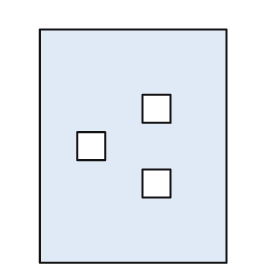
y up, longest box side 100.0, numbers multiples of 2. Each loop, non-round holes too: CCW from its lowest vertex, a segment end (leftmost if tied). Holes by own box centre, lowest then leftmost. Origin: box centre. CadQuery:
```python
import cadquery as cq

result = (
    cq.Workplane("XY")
    .moveTo(-40.0, -50.0)
    .lineTo(40.0, -50.0)
    .lineTo(40.0, 50.0)
    .lineTo(-40.0, 50.0)
    .close()
    .moveTo(4.0, -22.0)
    .lineTo(16.0, -22.0)
    .lineTo(16.0, -10.0)
    .lineTo(4.0, -10.0)
    .close()
    .moveTo(-24.0, -6.0)
    .lineTo(-12.0, -6.0)
    .lineTo(-12.0, 6.0)
    .lineTo(-24.0, 6.0)
    .close()
    .moveTo(4.0, 10.0)
    .lineTo(16.0, 10.0)
    .lineTo(16.0, 22.0)
    .lineTo(4.0, 22.0)
    .close()
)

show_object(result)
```